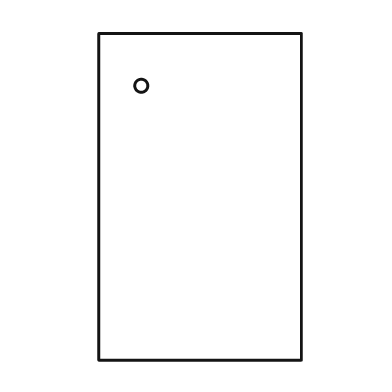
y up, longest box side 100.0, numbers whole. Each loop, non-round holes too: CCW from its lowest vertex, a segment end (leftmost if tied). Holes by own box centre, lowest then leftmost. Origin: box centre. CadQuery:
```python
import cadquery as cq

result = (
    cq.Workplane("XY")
    .moveTo(-31.0, -50.0)
    .lineTo(31.0, -50.0)
    .lineTo(31.0, 50.0)
    .lineTo(-31.0, 50.0)
    .close()
    .moveTo(-18.0, 34.0)
    .circle(2.0)
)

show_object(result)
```